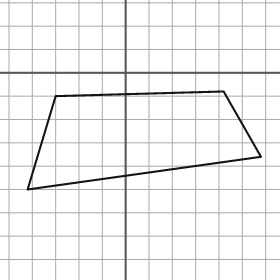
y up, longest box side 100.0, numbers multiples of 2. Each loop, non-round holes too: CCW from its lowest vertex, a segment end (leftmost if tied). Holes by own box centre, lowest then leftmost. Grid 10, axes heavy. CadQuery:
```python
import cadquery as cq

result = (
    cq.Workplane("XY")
    .moveTo(-42.0, -50.0)
    .lineTo(58.0, -36.0)
    .lineTo(42.0, -8.0)
    .lineTo(-30.0, -10.0)
    .close()
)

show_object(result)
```